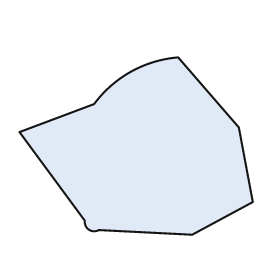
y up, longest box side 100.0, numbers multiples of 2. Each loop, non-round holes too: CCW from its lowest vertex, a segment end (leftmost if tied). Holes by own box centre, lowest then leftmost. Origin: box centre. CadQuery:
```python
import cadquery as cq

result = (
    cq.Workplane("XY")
    .moveTo(24.0, -38.0)
    .lineTo(50.0, -24.0)
    .lineTo(44.0, 8.0)
    .lineTo(18.0, 38.0)
    .threePointArc((-2.0, 32.0), (-18.0, 18.0))
    .lineTo(-50.0, 6.0)
    .lineTo(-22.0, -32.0)
    .threePointArc((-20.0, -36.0), (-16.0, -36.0))
    .close()
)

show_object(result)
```